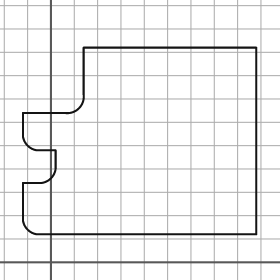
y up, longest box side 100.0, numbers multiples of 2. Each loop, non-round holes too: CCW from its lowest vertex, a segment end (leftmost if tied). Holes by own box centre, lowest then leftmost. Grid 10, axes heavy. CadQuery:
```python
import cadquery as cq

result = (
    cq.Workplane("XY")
    .moveTo(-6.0, 12.0)
    .lineTo(88.0, 12.0)
    .lineTo(88.0, 92.0)
    .lineTo(14.0, 92.0)
    .lineTo(14.0, 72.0)
    .threePointArc((12.0, 66.0), (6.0, 64.0))
    .lineTo(-12.0, 64.0)
    .lineTo(-12.0, 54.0)
    .threePointArc((-10.0, 50.0), (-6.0, 48.0))
    .lineTo(2.0, 48.0)
    .lineTo(2.0, 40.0)
    .threePointArc((0.0, 36.0), (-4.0, 34.0))
    .lineTo(-12.0, 34.0)
    .lineTo(-12.0, 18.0)
    .threePointArc((-10.0, 14.0), (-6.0, 12.0))
    .close()
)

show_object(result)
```